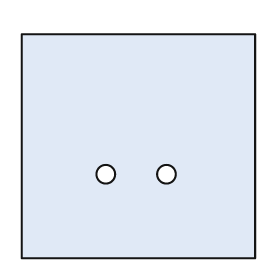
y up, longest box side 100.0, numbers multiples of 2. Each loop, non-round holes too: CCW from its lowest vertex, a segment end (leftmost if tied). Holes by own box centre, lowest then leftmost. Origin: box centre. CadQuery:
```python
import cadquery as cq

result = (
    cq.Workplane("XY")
    .moveTo(-50.0, -48.0)
    .lineTo(50.0, -48.0)
    .lineTo(50.0, 48.0)
    .lineTo(-50.0, 48.0)
    .close()
    .moveTo(-14.0, -12.0)
    .circle(4.0)
    .moveTo(12.0, -12.0)
    .circle(4.0)
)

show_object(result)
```